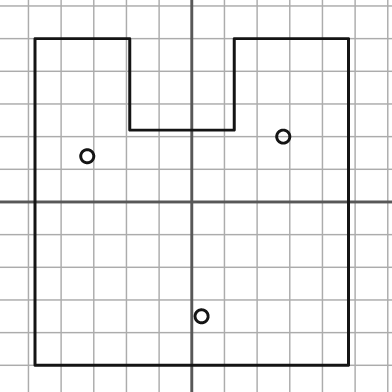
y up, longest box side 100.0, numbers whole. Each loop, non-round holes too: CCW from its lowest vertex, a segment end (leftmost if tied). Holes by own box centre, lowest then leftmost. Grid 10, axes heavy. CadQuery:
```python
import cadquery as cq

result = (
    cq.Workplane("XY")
    .moveTo(-48.0, -50.0)
    .lineTo(48.0, -50.0)
    .lineTo(48.0, 50.0)
    .lineTo(13.0, 50.0)
    .lineTo(13.0, 22.0)
    .lineTo(-19.0, 22.0)
    .lineTo(-19.0, 50.0)
    .lineTo(-48.0, 50.0)
    .close()
    .moveTo(3.0, -35.0)
    .circle(2.0)
    .moveTo(-32.0, 14.0)
    .circle(2.0)
    .moveTo(28.0, 20.0)
    .circle(2.0)
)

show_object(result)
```